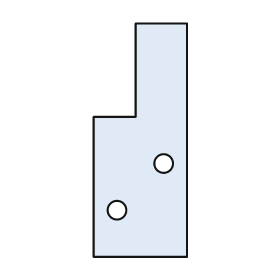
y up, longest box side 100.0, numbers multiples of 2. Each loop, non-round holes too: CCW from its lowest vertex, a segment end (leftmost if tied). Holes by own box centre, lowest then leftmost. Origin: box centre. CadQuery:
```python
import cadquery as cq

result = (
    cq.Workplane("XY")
    .moveTo(-20.0, -50.0)
    .lineTo(20.0, -50.0)
    .lineTo(20.0, 50.0)
    .lineTo(-2.0, 50.0)
    .lineTo(-2.0, 10.0)
    .lineTo(-20.0, 10.0)
    .close()
    .moveTo(-10.0, -30.0)
    .circle(4.0)
    .moveTo(10.0, -10.0)
    .circle(4.0)
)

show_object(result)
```